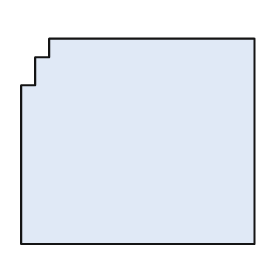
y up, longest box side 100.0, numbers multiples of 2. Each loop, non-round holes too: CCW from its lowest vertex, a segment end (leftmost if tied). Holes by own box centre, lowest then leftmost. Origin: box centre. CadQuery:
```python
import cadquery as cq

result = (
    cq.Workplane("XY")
    .moveTo(-50.0, -44.0)
    .lineTo(50.0, -44.0)
    .lineTo(50.0, 44.0)
    .lineTo(-38.0, 44.0)
    .lineTo(-38.0, 36.0)
    .lineTo(-44.0, 36.0)
    .lineTo(-44.0, 24.0)
    .lineTo(-50.0, 24.0)
    .close()
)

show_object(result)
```